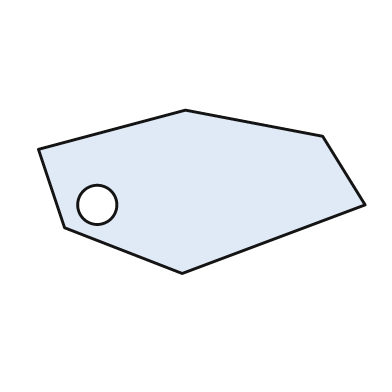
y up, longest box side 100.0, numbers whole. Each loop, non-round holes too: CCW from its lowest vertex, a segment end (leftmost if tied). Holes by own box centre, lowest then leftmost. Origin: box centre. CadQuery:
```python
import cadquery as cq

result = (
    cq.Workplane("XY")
    .moveTo(-6.0, -25.0)
    .lineTo(50.0, -4.0)
    .lineTo(37.0, 17.0)
    .lineTo(-5.0, 25.0)
    .lineTo(-50.0, 13.0)
    .lineTo(-42.0, -11.0)
    .close()
    .moveTo(-32.0, -4.0)
    .circle(6.0)
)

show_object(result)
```